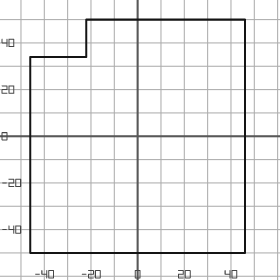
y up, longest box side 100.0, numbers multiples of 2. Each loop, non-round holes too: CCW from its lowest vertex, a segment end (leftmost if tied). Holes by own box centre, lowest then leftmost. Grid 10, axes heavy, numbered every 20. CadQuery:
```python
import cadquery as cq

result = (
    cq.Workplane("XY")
    .moveTo(-46.0, -50.0)
    .lineTo(46.0, -50.0)
    .lineTo(46.0, 50.0)
    .lineTo(-22.0, 50.0)
    .lineTo(-22.0, 34.0)
    .lineTo(-46.0, 34.0)
    .close()
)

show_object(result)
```